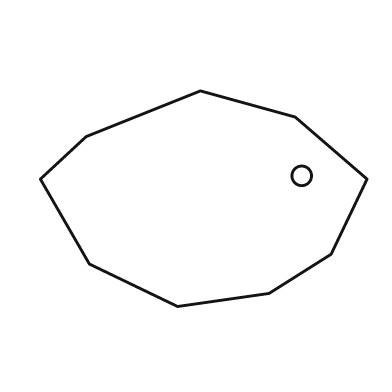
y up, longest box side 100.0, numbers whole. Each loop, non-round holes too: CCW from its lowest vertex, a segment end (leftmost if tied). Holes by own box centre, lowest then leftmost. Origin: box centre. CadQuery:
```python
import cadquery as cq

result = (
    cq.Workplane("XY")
    .moveTo(-8.0, -33.0)
    .lineTo(20.0, -29.0)
    .lineTo(39.0, -17.0)
    .lineTo(50.0, 6.0)
    .lineTo(28.0, 25.0)
    .lineTo(-1.0, 33.0)
    .lineTo(-36.0, 19.0)
    .lineTo(-50.0, 6.0)
    .lineTo(-35.0, -20.0)
    .close()
    .moveTo(30.0, 7.0)
    .circle(3.0)
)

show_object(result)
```